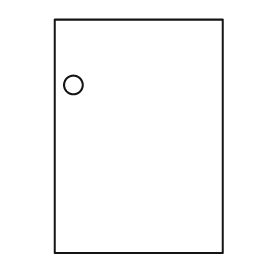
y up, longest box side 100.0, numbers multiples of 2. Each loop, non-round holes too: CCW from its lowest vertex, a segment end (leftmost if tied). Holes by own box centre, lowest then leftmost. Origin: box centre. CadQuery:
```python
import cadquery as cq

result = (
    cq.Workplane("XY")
    .moveTo(-36.0, -50.0)
    .lineTo(36.0, -50.0)
    .lineTo(36.0, 50.0)
    .lineTo(-36.0, 50.0)
    .close()
    .moveTo(-28.0, 22.0)
    .circle(4.0)
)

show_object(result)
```